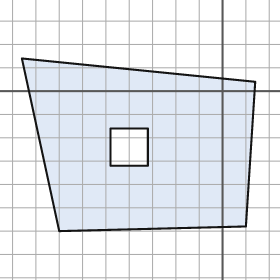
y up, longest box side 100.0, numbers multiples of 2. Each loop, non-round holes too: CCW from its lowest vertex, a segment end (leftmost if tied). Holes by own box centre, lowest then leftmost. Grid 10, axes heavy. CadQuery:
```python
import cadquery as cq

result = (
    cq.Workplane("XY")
    .moveTo(-70.0, -60.0)
    .lineTo(10.0, -58.0)
    .lineTo(14.0, 4.0)
    .lineTo(-86.0, 14.0)
    .close()
    .moveTo(-48.0, -32.0)
    .lineTo(-32.0, -32.0)
    .lineTo(-32.0, -16.0)
    .lineTo(-48.0, -16.0)
    .close()
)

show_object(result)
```